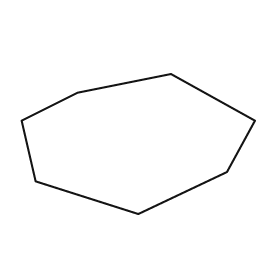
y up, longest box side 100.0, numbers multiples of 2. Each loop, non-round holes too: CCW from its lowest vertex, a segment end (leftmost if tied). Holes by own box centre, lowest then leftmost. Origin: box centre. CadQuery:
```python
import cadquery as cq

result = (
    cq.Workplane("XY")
    .moveTo(0.0, -30.0)
    .lineTo(38.0, -12.0)
    .lineTo(50.0, 10.0)
    .lineTo(14.0, 30.0)
    .lineTo(-26.0, 22.0)
    .lineTo(-50.0, 10.0)
    .lineTo(-44.0, -16.0)
    .close()
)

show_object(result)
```